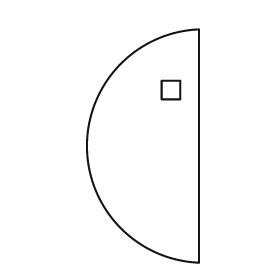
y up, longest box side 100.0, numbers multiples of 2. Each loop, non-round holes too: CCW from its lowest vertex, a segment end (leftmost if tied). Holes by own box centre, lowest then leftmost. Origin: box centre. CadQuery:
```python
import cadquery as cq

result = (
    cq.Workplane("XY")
    .moveTo(24.0, -50.0)
    .lineTo(24.0, 50.0)
    .threePointArc((-24.0, 0.0), (24.0, -50.0))
    .close()
    .moveTo(8.0, 20.0)
    .lineTo(16.0, 20.0)
    .lineTo(16.0, 28.0)
    .lineTo(8.0, 28.0)
    .close()
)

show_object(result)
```